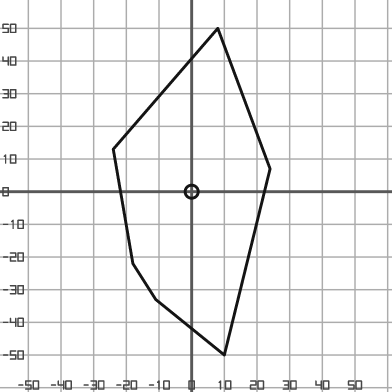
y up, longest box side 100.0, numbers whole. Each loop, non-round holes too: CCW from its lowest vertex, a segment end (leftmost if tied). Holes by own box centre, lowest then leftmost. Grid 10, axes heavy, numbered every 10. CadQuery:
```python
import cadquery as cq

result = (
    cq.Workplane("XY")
    .moveTo(10.0, -50.0)
    .lineTo(24.0, 7.0)
    .lineTo(8.0, 50.0)
    .lineTo(-24.0, 13.0)
    .lineTo(-18.0, -22.0)
    .lineTo(-11.0, -33.0)
    .close()
    .moveTo(0.0, 0.0)
    .circle(2.0)
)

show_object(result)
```